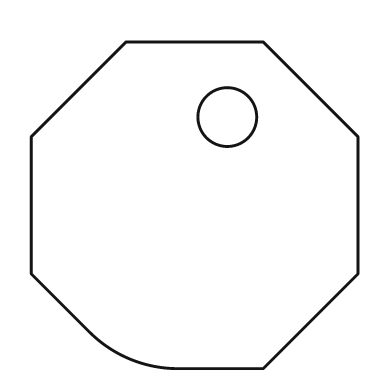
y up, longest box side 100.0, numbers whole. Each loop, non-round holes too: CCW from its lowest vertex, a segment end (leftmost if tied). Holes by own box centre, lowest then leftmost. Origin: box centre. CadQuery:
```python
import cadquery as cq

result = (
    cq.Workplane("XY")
    .moveTo(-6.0, -50.0)
    .lineTo(21.0, -50.0)
    .lineTo(50.0, -21.0)
    .lineTo(50.0, 21.0)
    .lineTo(21.0, 50.0)
    .lineTo(-21.0, 50.0)
    .lineTo(-50.0, 21.0)
    .lineTo(-50.0, -21.0)
    .lineTo(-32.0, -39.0)
    .threePointArc((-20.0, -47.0), (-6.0, -50.0))
    .close()
    .moveTo(10.0, 27.0)
    .circle(9.0)
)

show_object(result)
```